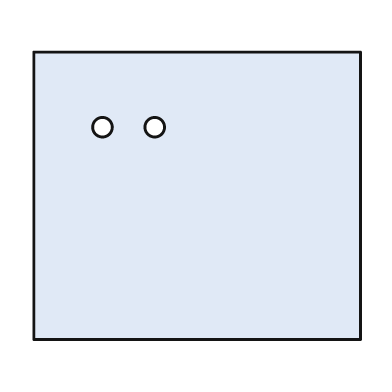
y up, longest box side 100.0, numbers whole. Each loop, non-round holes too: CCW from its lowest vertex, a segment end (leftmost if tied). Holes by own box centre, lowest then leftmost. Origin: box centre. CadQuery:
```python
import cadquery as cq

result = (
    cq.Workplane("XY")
    .moveTo(-50.0, -44.0)
    .lineTo(50.0, -44.0)
    .lineTo(50.0, 44.0)
    .lineTo(-50.0, 44.0)
    .close()
    .moveTo(-29.0, 21.0)
    .circle(3.0)
    .moveTo(-13.0, 21.0)
    .circle(3.0)
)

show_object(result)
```